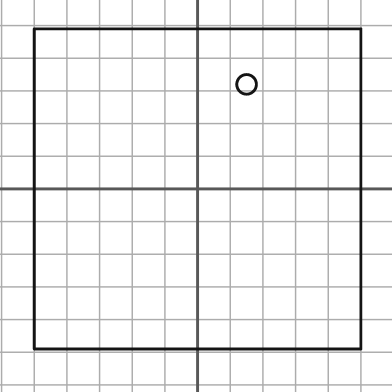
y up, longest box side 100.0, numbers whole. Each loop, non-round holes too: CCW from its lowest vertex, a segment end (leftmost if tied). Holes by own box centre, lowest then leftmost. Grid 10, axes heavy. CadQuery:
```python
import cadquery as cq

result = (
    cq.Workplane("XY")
    .moveTo(-50.0, -49.0)
    .lineTo(50.0, -49.0)
    .lineTo(50.0, 49.0)
    .lineTo(-50.0, 49.0)
    .close()
    .moveTo(15.0, 32.0)
    .circle(3.0)
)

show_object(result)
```